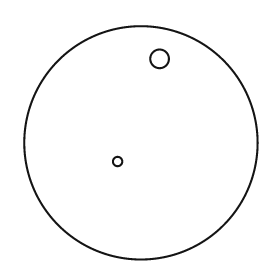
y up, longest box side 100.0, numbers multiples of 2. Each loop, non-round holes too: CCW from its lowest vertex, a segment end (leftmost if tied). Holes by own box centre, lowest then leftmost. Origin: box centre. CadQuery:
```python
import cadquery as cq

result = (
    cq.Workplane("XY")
    .moveTo(0.0, 0.0)
    .circle(50.0)
    .moveTo(-10.0, -8.0)
    .circle(2.0)
    .moveTo(8.0, 36.0)
    .circle(4.0)
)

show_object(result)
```